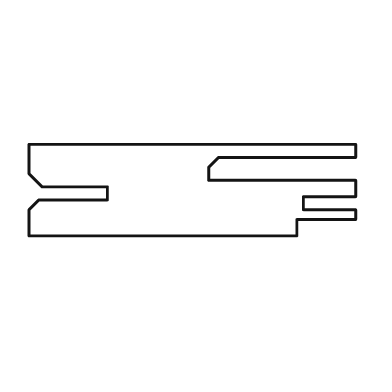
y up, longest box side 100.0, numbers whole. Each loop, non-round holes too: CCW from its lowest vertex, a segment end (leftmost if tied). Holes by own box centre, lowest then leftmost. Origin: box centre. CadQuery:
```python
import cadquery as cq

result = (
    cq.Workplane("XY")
    .moveTo(-50.0, -14.0)
    .lineTo(32.0, -14.0)
    .lineTo(32.0, -9.0)
    .lineTo(50.0, -9.0)
    .lineTo(50.0, -6.0)
    .lineTo(34.0, -6.0)
    .lineTo(34.0, -2.0)
    .lineTo(50.0, -2.0)
    .lineTo(50.0, 3.0)
    .lineTo(5.0, 3.0)
    .lineTo(5.0, 7.0)
    .lineTo(8.0, 10.0)
    .lineTo(50.0, 10.0)
    .lineTo(50.0, 14.0)
    .lineTo(-50.0, 14.0)
    .lineTo(-50.0, 5.0)
    .lineTo(-46.0, 1.0)
    .lineTo(-26.0, 1.0)
    .lineTo(-26.0, -3.0)
    .lineTo(-47.0, -3.0)
    .lineTo(-50.0, -6.0)
    .close()
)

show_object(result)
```